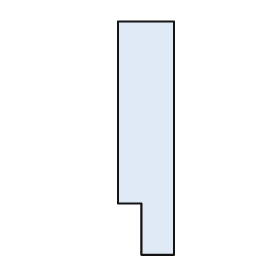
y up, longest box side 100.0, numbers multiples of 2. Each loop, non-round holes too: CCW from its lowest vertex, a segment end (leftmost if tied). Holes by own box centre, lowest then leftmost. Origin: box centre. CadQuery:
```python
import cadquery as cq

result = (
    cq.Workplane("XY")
    .moveTo(-2.0, -50.0)
    .lineTo(12.0, -50.0)
    .lineTo(12.0, 50.0)
    .lineTo(-12.0, 50.0)
    .lineTo(-12.0, -28.0)
    .lineTo(-2.0, -28.0)
    .close()
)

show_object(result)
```